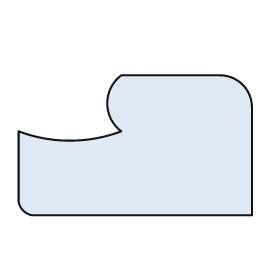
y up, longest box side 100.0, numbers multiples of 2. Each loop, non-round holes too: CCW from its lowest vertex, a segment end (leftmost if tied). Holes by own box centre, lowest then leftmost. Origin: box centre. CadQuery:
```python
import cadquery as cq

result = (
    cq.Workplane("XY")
    .moveTo(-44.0, -30.0)
    .lineTo(50.0, -30.0)
    .lineTo(50.0, 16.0)
    .threePointArc((46.0, 26.0), (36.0, 30.0))
    .lineTo(-6.0, 30.0)
    .threePointArc((-12.0, 18.0), (-6.0, 6.0))
    .threePointArc((-28.0, 2.0), (-50.0, 6.0))
    .lineTo(-50.0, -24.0)
    .threePointArc((-48.0, -28.0), (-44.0, -30.0))
    .close()
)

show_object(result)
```